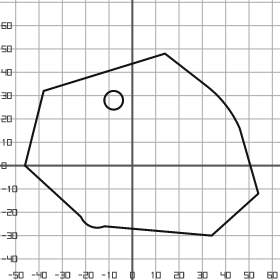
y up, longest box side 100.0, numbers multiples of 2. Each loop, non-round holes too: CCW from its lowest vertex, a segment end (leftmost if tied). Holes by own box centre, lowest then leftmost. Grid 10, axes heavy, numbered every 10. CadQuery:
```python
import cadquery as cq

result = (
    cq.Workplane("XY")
    .moveTo(34.0, -30.0)
    .lineTo(54.0, -12.0)
    .lineTo(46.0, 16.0)
    .threePointArc((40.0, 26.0), (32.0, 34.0))
    .lineTo(14.0, 48.0)
    .lineTo(-38.0, 32.0)
    .lineTo(-46.0, 0.0)
    .lineTo(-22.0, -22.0)
    .threePointArc((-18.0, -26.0), (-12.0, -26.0))
    .close()
    .moveTo(-8.0, 28.0)
    .circle(4.0)
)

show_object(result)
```